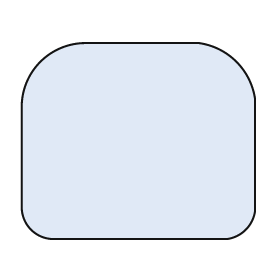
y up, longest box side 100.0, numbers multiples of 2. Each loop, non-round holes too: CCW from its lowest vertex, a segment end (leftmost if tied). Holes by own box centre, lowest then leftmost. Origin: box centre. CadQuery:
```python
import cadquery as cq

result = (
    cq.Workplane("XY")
    .moveTo(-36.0, -42.0)
    .lineTo(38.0, -42.0)
    .threePointArc((46.0, -38.0), (50.0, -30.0))
    .lineTo(50.0, 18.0)
    .threePointArc((42.0, 34.0), (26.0, 42.0))
    .lineTo(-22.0, 42.0)
    .threePointArc((-42.0, 34.0), (-50.0, 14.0))
    .lineTo(-50.0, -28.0)
    .threePointArc((-46.0, -38.0), (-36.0, -42.0))
    .close()
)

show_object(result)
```